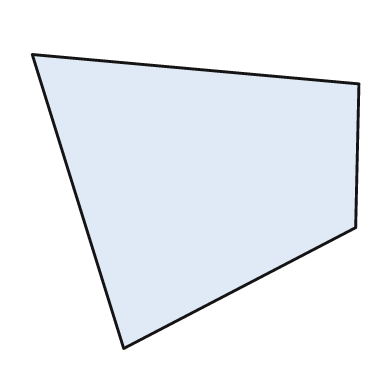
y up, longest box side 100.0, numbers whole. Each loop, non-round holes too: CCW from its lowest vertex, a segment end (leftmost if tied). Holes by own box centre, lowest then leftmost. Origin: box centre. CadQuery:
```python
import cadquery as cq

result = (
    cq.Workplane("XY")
    .moveTo(-22.0, -45.0)
    .lineTo(49.0, -8.0)
    .lineTo(50.0, 36.0)
    .lineTo(-50.0, 45.0)
    .close()
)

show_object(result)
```